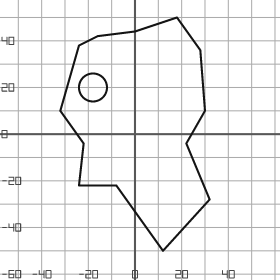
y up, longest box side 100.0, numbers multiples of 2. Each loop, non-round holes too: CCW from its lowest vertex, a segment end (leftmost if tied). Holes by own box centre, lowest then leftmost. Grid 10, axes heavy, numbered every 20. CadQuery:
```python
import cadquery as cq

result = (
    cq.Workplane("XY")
    .moveTo(12.0, -50.0)
    .lineTo(32.0, -28.0)
    .lineTo(22.0, -4.0)
    .lineTo(30.0, 10.0)
    .lineTo(28.0, 36.0)
    .lineTo(18.0, 50.0)
    .lineTo(0.0, 44.0)
    .lineTo(-16.0, 42.0)
    .lineTo(-24.0, 38.0)
    .lineTo(-32.0, 10.0)
    .lineTo(-22.0, -4.0)
    .lineTo(-24.0, -22.0)
    .lineTo(-8.0, -22.0)
    .close()
    .moveTo(-18.0, 20.0)
    .circle(6.0)
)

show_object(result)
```